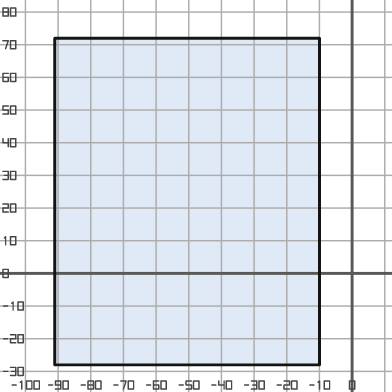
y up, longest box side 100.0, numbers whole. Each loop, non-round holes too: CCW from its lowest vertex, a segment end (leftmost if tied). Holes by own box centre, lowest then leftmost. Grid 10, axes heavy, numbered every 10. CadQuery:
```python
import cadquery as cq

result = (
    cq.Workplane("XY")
    .moveTo(-91.0, -28.0)
    .lineTo(-10.0, -28.0)
    .lineTo(-10.0, 72.0)
    .lineTo(-91.0, 72.0)
    .close()
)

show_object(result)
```